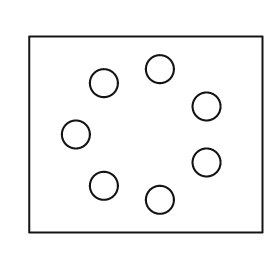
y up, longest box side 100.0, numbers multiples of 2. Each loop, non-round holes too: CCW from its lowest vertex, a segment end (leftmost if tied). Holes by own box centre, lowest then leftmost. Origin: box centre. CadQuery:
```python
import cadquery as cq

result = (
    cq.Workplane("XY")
    .moveTo(-50.0, -42.0)
    .lineTo(50.0, -42.0)
    .lineTo(50.0, 42.0)
    .lineTo(-50.0, 42.0)
    .close()
    .moveTo(6.0, -28.0)
    .circle(6.0)
    .moveTo(-18.0, -22.0)
    .circle(6.0)
    .moveTo(26.0, -12.0)
    .circle(6.0)
    .moveTo(-30.0, 0.0)
    .circle(6.0)
    .moveTo(26.0, 12.0)
    .circle(6.0)
    .moveTo(-18.0, 22.0)
    .circle(6.0)
    .moveTo(6.0, 28.0)
    .circle(6.0)
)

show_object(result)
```